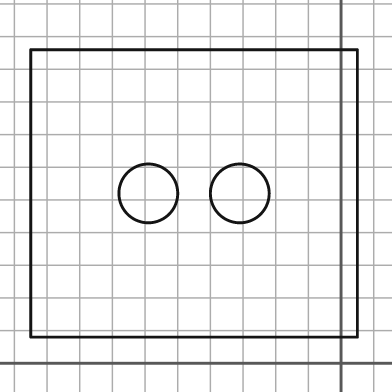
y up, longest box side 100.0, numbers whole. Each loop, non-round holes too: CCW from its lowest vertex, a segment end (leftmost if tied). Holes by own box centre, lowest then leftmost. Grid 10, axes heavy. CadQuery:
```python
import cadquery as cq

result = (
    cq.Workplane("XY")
    .moveTo(-95.0, 8.0)
    .lineTo(5.0, 8.0)
    .lineTo(5.0, 96.0)
    .lineTo(-95.0, 96.0)
    .close()
    .moveTo(-59.0, 52.0)
    .circle(9.0)
    .moveTo(-31.0, 52.0)
    .circle(9.0)
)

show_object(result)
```